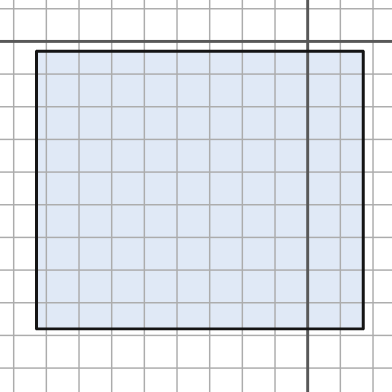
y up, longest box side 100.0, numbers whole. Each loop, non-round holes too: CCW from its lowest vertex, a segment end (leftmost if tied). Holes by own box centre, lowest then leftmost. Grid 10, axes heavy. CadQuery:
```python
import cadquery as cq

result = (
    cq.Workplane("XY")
    .moveTo(-83.0, -88.0)
    .lineTo(17.0, -88.0)
    .lineTo(17.0, -3.0)
    .lineTo(-83.0, -3.0)
    .close()
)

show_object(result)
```